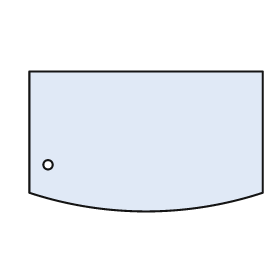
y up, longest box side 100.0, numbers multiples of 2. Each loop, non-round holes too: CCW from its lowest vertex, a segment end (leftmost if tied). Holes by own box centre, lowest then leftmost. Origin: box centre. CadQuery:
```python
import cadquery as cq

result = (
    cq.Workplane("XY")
    .moveTo(-50.0, -22.0)
    .threePointArc((0.0, -30.0), (50.0, -22.0))
    .lineTo(50.0, 30.0)
    .lineTo(-50.0, 30.0)
    .close()
    .moveTo(-42.0, -10.0)
    .circle(2.0)
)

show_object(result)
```